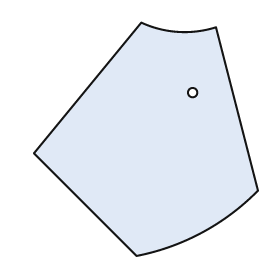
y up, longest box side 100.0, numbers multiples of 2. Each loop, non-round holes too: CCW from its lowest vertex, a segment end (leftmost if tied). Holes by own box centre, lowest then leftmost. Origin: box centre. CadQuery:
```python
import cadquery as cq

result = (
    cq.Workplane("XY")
    .moveTo(-4.0, -50.0)
    .threePointArc((24.0, -40.0), (48.0, -22.0))
    .lineTo(30.0, 48.0)
    .threePointArc((14.0, 46.0), (-2.0, 50.0))
    .lineTo(-48.0, -6.0)
    .close()
    .moveTo(20.0, 20.0)
    .circle(2.0)
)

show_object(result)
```